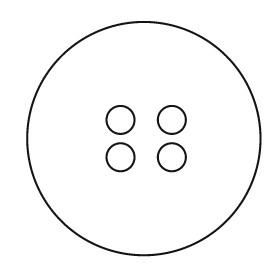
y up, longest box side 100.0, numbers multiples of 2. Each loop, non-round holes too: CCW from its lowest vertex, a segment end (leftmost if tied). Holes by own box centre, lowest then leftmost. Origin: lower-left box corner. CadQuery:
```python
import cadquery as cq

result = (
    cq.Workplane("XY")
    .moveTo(50.0, 50.0)
    .circle(50.0)
    .moveTo(40.0, 42.0)
    .circle(6.0)
    .moveTo(62.0, 42.0)
    .circle(6.0)
    .moveTo(40.0, 58.0)
    .circle(6.0)
    .moveTo(62.0, 58.0)
    .circle(6.0)
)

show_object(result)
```